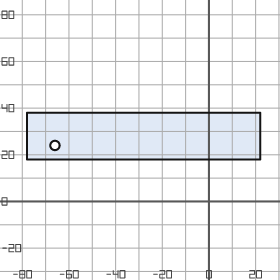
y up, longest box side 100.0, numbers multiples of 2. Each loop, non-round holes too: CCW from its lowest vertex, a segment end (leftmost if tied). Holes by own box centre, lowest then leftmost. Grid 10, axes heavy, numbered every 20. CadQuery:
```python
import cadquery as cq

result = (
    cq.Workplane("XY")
    .moveTo(-78.0, 18.0)
    .lineTo(22.0, 18.0)
    .lineTo(22.0, 38.0)
    .lineTo(-78.0, 38.0)
    .close()
    .moveTo(-66.0, 24.0)
    .circle(2.0)
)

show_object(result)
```